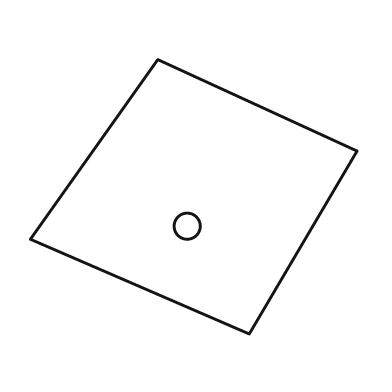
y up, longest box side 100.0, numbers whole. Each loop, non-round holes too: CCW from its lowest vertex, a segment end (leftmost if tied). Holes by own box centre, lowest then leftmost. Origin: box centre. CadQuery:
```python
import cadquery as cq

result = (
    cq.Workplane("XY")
    .moveTo(17.0, -42.0)
    .lineTo(50.0, 14.0)
    .lineTo(-11.0, 42.0)
    .lineTo(-50.0, -13.0)
    .close()
    .moveTo(-2.0, -9.0)
    .circle(4.0)
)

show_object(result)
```